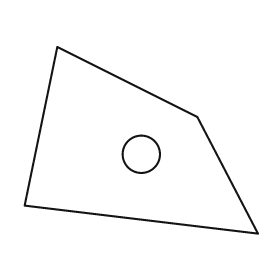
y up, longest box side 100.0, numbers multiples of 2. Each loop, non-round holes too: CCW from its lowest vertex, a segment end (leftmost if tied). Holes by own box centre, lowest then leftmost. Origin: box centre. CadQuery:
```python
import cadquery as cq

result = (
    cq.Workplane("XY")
    .moveTo(50.0, -40.0)
    .lineTo(24.0, 10.0)
    .lineTo(-36.0, 40.0)
    .lineTo(-50.0, -28.0)
    .close()
    .moveTo(0.0, -6.0)
    .circle(8.0)
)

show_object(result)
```